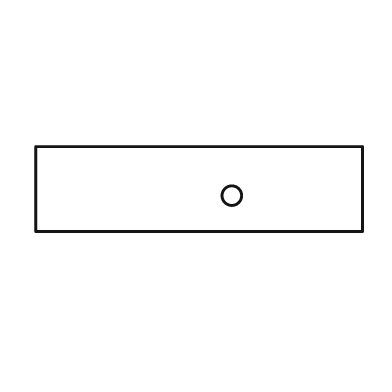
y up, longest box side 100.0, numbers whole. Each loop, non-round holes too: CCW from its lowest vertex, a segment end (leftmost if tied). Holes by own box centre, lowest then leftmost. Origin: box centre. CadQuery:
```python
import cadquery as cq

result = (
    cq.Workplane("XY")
    .moveTo(-50.0, -13.0)
    .lineTo(50.0, -13.0)
    .lineTo(50.0, 13.0)
    .lineTo(-50.0, 13.0)
    .close()
    .moveTo(10.0, -2.0)
    .circle(3.0)
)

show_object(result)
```